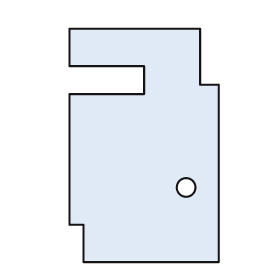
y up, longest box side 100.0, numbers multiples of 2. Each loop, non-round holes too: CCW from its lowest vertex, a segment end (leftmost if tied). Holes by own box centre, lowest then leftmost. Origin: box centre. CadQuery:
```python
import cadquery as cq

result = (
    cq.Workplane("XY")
    .moveTo(-26.0, -50.0)
    .lineTo(32.0, -50.0)
    .lineTo(32.0, 26.0)
    .lineTo(24.0, 26.0)
    .lineTo(24.0, 50.0)
    .lineTo(-32.0, 50.0)
    .lineTo(-32.0, 34.0)
    .lineTo(0.0, 34.0)
    .lineTo(0.0, 22.0)
    .lineTo(-32.0, 22.0)
    .lineTo(-32.0, -34.0)
    .lineTo(-26.0, -34.0)
    .close()
    .moveTo(18.0, -18.0)
    .circle(4.0)
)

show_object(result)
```